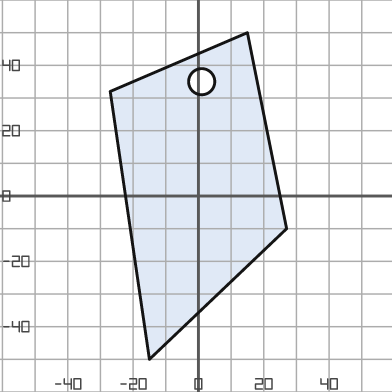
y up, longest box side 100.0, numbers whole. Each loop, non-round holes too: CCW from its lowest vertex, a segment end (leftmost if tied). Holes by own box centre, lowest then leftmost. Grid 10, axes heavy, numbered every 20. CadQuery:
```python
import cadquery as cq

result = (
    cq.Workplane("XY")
    .moveTo(-15.0, -50.0)
    .lineTo(27.0, -10.0)
    .lineTo(15.0, 50.0)
    .lineTo(-27.0, 32.0)
    .close()
    .moveTo(1.0, 35.0)
    .circle(4.0)
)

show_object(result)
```